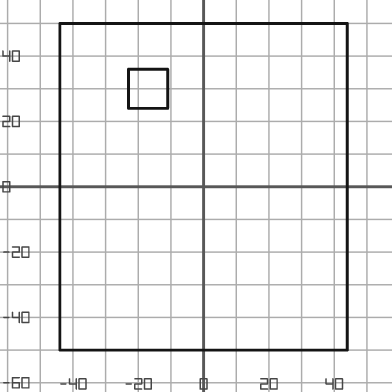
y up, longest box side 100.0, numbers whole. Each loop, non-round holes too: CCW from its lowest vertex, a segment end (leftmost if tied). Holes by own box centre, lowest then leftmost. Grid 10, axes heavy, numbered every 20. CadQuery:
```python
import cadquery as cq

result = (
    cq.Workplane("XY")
    .moveTo(-44.0, -50.0)
    .lineTo(44.0, -50.0)
    .lineTo(44.0, 50.0)
    .lineTo(-44.0, 50.0)
    .close()
    .moveTo(-23.0, 24.0)
    .lineTo(-11.0, 24.0)
    .lineTo(-11.0, 36.0)
    .lineTo(-23.0, 36.0)
    .close()
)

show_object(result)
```